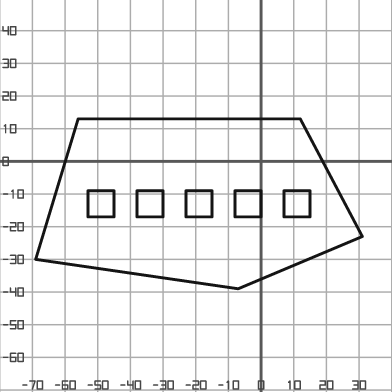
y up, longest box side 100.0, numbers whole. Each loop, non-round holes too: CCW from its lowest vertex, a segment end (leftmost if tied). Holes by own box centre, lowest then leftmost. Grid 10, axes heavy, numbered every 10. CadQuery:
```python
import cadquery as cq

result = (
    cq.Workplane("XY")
    .moveTo(-7.0, -39.0)
    .lineTo(31.0, -23.0)
    .lineTo(12.0, 13.0)
    .lineTo(-56.0, 13.0)
    .lineTo(-69.0, -30.0)
    .close()
    .moveTo(-53.0, -17.0)
    .lineTo(-45.0, -17.0)
    .lineTo(-45.0, -9.0)
    .lineTo(-53.0, -9.0)
    .close()
    .moveTo(-38.0, -17.0)
    .lineTo(-30.0, -17.0)
    .lineTo(-30.0, -9.0)
    .lineTo(-38.0, -9.0)
    .close()
    .moveTo(-23.0, -17.0)
    .lineTo(-15.0, -17.0)
    .lineTo(-15.0, -9.0)
    .lineTo(-23.0, -9.0)
    .close()
    .moveTo(-8.0, -17.0)
    .lineTo(0.0, -17.0)
    .lineTo(0.0, -9.0)
    .lineTo(-8.0, -9.0)
    .close()
    .moveTo(7.0, -17.0)
    .lineTo(15.0, -17.0)
    .lineTo(15.0, -9.0)
    .lineTo(7.0, -9.0)
    .close()
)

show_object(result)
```